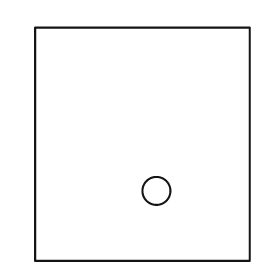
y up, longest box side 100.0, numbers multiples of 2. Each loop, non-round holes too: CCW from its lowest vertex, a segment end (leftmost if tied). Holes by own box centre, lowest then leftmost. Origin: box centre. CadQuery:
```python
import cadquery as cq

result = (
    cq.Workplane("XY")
    .moveTo(-46.0, -50.0)
    .lineTo(46.0, -50.0)
    .lineTo(46.0, 50.0)
    .lineTo(-46.0, 50.0)
    .close()
    .moveTo(6.0, -20.0)
    .circle(6.0)
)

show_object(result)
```